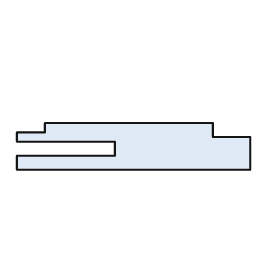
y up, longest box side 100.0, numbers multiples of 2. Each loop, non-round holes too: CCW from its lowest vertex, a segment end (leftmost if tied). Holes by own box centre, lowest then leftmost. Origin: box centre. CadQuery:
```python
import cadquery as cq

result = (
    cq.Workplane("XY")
    .moveTo(-50.0, -10.0)
    .lineTo(50.0, -10.0)
    .lineTo(50.0, 4.0)
    .lineTo(34.0, 4.0)
    .lineTo(34.0, 10.0)
    .lineTo(-38.0, 10.0)
    .lineTo(-38.0, 6.0)
    .lineTo(-50.0, 6.0)
    .lineTo(-50.0, 2.0)
    .lineTo(-8.0, 2.0)
    .lineTo(-8.0, -4.0)
    .lineTo(-50.0, -4.0)
    .close()
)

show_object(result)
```